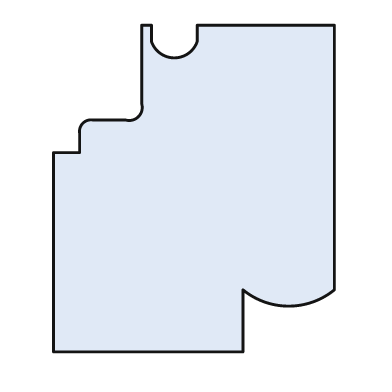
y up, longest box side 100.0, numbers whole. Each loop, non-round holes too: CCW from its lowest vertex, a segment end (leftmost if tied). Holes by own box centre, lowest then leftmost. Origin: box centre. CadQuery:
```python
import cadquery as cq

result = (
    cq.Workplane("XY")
    .moveTo(-43.0, -50.0)
    .lineTo(15.0, -50.0)
    .lineTo(15.0, -31.0)
    .threePointArc((29.0, -36.0), (43.0, -31.0))
    .lineTo(43.0, 50.0)
    .lineTo(1.0, 50.0)
    .lineTo(1.0, 45.0)
    .threePointArc((-6.0, 40.0), (-13.0, 45.0))
    .lineTo(-13.0, 50.0)
    .lineTo(-16.0, 50.0)
    .lineTo(-16.0, 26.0)
    .threePointArc((-17.0, 22.0), (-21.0, 21.0))
    .lineTo(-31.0, 21.0)
    .threePointArc((-34.0, 20.0), (-35.0, 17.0))
    .lineTo(-35.0, 11.0)
    .lineTo(-43.0, 11.0)
    .close()
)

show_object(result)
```